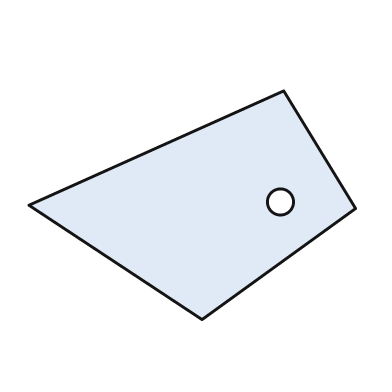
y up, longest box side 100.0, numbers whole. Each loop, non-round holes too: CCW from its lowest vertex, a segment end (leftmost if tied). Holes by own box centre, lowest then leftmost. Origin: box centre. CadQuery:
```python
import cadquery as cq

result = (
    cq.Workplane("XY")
    .moveTo(3.0, -35.0)
    .lineTo(50.0, -1.0)
    .lineTo(28.0, 35.0)
    .lineTo(-50.0, 0.0)
    .close()
    .moveTo(27.0, 1.0)
    .circle(4.0)
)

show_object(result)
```